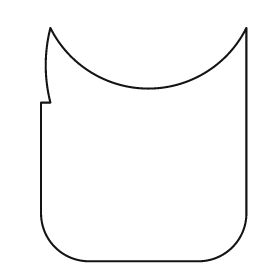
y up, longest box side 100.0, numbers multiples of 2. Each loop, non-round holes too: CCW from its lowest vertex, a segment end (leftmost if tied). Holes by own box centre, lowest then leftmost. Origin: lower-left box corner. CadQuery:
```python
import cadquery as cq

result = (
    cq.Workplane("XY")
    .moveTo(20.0, 0.0)
    .lineTo(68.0, 0.0)
    .threePointArc((82.0, 6.0), (88.0, 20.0))
    .lineTo(88.0, 100.0)
    .threePointArc((46.0, 74.0), (4.0, 100.0))
    .threePointArc((2.0, 84.0), (4.0, 68.0))
    .lineTo(0.0, 68.0)
    .lineTo(0.0, 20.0)
    .threePointArc((6.0, 6.0), (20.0, 0.0))
    .close()
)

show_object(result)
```